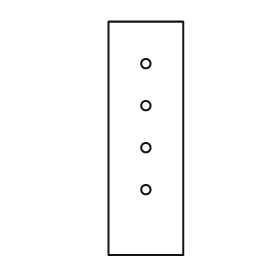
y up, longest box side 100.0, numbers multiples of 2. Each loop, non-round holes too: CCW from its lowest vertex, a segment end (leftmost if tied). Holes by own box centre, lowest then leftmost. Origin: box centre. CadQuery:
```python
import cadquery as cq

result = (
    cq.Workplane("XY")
    .moveTo(-16.0, -50.0)
    .lineTo(16.0, -50.0)
    .lineTo(16.0, 50.0)
    .lineTo(-16.0, 50.0)
    .close()
    .moveTo(0.0, -22.0)
    .circle(2.0)
    .moveTo(0.0, -4.0)
    .circle(2.0)
    .moveTo(0.0, 14.0)
    .circle(2.0)
    .moveTo(0.0, 32.0)
    .circle(2.0)
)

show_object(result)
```